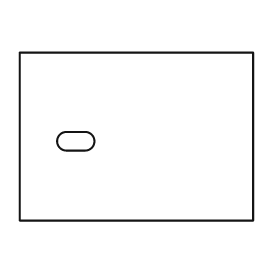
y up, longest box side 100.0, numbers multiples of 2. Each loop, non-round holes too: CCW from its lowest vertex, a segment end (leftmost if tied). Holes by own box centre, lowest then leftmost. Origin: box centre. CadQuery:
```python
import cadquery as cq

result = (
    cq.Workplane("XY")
    .moveTo(-50.0, -36.0)
    .lineTo(50.0, -36.0)
    .lineTo(50.0, 36.0)
    .lineTo(-50.0, 36.0)
    .close()
    .moveTo(-30.0, -6.0)
    .lineTo(-22.0, -6.0)
    .threePointArc((-18.0, -2.0), (-22.0, 2.0))
    .lineTo(-30.0, 2.0)
    .threePointArc((-34.0, -2.0), (-30.0, -6.0))
    .close()
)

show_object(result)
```